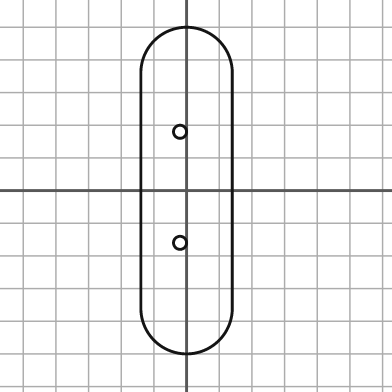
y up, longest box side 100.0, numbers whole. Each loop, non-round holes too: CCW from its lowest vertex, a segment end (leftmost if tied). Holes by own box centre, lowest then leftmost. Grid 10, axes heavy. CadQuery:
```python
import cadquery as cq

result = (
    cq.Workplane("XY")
    .moveTo(-14.0, -36.0)
    .threePointArc((0.0, -50.0), (14.0, -36.0))
    .lineTo(14.0, 36.0)
    .threePointArc((0.0, 50.0), (-14.0, 36.0))
    .close()
    .moveTo(-2.0, -16.0)
    .circle(2.0)
    .moveTo(-2.0, 18.0)
    .circle(2.0)
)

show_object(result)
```